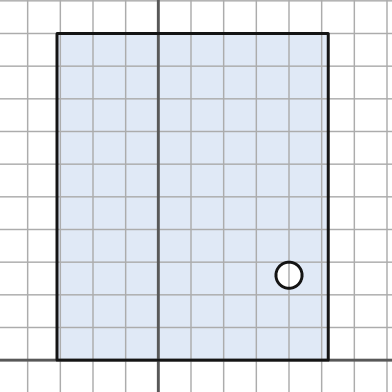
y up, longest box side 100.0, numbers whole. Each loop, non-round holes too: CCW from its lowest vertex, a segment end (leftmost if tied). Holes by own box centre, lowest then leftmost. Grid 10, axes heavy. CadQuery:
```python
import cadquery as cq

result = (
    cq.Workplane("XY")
    .moveTo(-31.0, 0.0)
    .lineTo(52.0, 0.0)
    .lineTo(52.0, 100.0)
    .lineTo(-31.0, 100.0)
    .close()
    .moveTo(40.0, 26.0)
    .circle(4.0)
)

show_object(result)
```